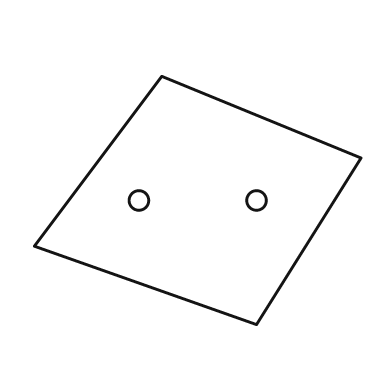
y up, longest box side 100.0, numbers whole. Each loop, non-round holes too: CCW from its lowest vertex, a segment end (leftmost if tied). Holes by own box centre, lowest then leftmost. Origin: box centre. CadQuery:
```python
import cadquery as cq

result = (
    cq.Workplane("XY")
    .moveTo(18.0, -38.0)
    .lineTo(50.0, 13.0)
    .lineTo(-11.0, 38.0)
    .lineTo(-50.0, -14.0)
    .close()
    .moveTo(-18.0, 0.0)
    .circle(3.0)
    .moveTo(18.0, 0.0)
    .circle(3.0)
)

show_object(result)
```